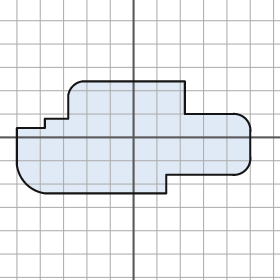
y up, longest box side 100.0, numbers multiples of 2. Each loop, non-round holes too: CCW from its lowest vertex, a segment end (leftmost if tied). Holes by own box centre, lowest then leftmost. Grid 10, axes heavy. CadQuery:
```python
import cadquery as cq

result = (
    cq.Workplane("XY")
    .moveTo(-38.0, -24.0)
    .lineTo(14.0, -24.0)
    .lineTo(14.0, -16.0)
    .lineTo(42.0, -16.0)
    .threePointArc((48.0, -14.0), (50.0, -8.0))
    .lineTo(50.0, 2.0)
    .threePointArc((48.0, 8.0), (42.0, 10.0))
    .lineTo(22.0, 10.0)
    .lineTo(22.0, 24.0)
    .lineTo(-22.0, 24.0)
    .threePointArc((-26.0, 22.0), (-28.0, 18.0))
    .lineTo(-28.0, 8.0)
    .lineTo(-38.0, 8.0)
    .lineTo(-38.0, 4.0)
    .lineTo(-50.0, 4.0)
    .lineTo(-50.0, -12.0)
    .threePointArc((-46.0, -20.0), (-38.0, -24.0))
    .close()
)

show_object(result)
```